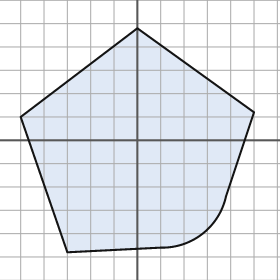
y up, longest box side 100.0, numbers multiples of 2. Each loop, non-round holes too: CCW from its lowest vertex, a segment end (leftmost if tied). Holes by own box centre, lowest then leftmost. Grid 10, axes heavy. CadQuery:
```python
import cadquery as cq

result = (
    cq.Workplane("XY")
    .moveTo(-30.0, -48.0)
    .lineTo(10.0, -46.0)
    .threePointArc((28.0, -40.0), (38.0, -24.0))
    .lineTo(50.0, 12.0)
    .lineTo(0.0, 48.0)
    .lineTo(-50.0, 10.0)
    .close()
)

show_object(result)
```